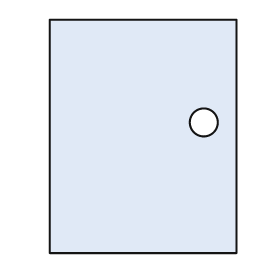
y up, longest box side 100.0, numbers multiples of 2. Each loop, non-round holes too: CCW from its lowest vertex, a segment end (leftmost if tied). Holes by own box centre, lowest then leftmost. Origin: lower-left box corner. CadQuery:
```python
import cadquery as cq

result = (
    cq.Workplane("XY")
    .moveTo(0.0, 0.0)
    .lineTo(80.0, 0.0)
    .lineTo(80.0, 100.0)
    .lineTo(0.0, 100.0)
    .close()
    .moveTo(66.0, 56.0)
    .circle(6.0)
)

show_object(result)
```